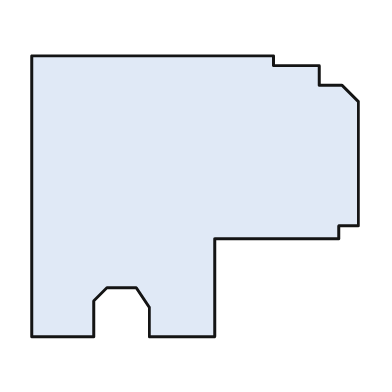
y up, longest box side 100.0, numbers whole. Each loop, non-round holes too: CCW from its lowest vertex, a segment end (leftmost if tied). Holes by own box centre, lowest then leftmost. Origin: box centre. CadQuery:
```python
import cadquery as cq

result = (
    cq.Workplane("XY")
    .moveTo(-50.0, -43.0)
    .lineTo(-31.0, -43.0)
    .lineTo(-31.0, -32.0)
    .lineTo(-27.0, -28.0)
    .lineTo(-18.0, -28.0)
    .lineTo(-14.0, -34.0)
    .lineTo(-14.0, -43.0)
    .lineTo(6.0, -43.0)
    .lineTo(6.0, -13.0)
    .lineTo(44.0, -13.0)
    .lineTo(44.0, -9.0)
    .lineTo(50.0, -9.0)
    .lineTo(50.0, 29.0)
    .lineTo(45.0, 34.0)
    .lineTo(38.0, 34.0)
    .lineTo(38.0, 40.0)
    .lineTo(24.0, 40.0)
    .lineTo(24.0, 43.0)
    .lineTo(-50.0, 43.0)
    .close()
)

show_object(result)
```